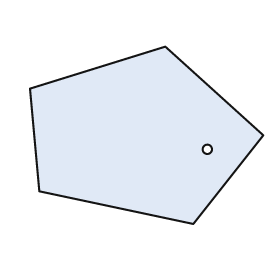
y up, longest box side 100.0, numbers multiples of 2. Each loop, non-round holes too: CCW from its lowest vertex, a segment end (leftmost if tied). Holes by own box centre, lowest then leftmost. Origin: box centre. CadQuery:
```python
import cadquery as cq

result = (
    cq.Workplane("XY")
    .moveTo(20.0, -38.0)
    .lineTo(50.0, 0.0)
    .lineTo(8.0, 38.0)
    .lineTo(-50.0, 20.0)
    .lineTo(-46.0, -24.0)
    .close()
    .moveTo(26.0, -6.0)
    .circle(2.0)
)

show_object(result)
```